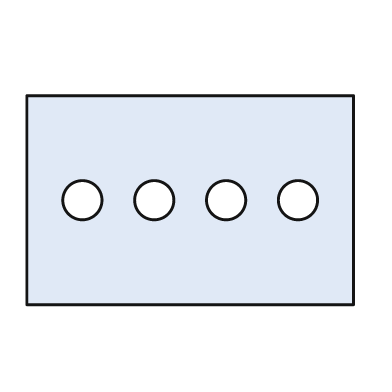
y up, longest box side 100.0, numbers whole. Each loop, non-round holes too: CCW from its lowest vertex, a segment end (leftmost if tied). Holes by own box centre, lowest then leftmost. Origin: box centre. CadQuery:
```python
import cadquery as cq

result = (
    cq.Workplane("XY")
    .moveTo(-50.0, -32.0)
    .lineTo(50.0, -32.0)
    .lineTo(50.0, 32.0)
    .lineTo(-50.0, 32.0)
    .close()
    .moveTo(-33.0, 0.0)
    .circle(6.0)
    .moveTo(-11.0, 0.0)
    .circle(6.0)
    .moveTo(11.0, 0.0)
    .circle(6.0)
    .moveTo(33.0, 0.0)
    .circle(6.0)
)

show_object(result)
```